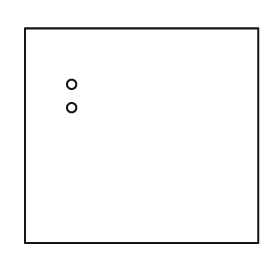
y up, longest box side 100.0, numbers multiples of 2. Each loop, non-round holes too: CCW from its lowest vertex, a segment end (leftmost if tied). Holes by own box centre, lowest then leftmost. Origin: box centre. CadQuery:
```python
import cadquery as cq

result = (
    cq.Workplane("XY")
    .moveTo(-50.0, -46.0)
    .lineTo(50.0, -46.0)
    .lineTo(50.0, 46.0)
    .lineTo(-50.0, 46.0)
    .close()
    .moveTo(-30.0, 12.0)
    .circle(2.0)
    .moveTo(-30.0, 22.0)
    .circle(2.0)
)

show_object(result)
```